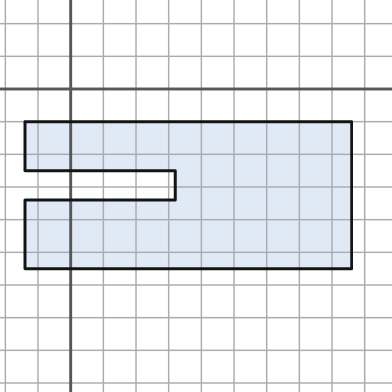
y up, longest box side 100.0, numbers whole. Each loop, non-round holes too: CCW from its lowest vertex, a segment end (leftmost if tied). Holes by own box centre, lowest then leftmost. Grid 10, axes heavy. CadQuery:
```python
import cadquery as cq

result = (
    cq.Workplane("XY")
    .moveTo(-14.0, -55.0)
    .lineTo(86.0, -55.0)
    .lineTo(86.0, -10.0)
    .lineTo(-14.0, -10.0)
    .lineTo(-14.0, -25.0)
    .lineTo(32.0, -25.0)
    .lineTo(32.0, -34.0)
    .lineTo(-14.0, -34.0)
    .close()
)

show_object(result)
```